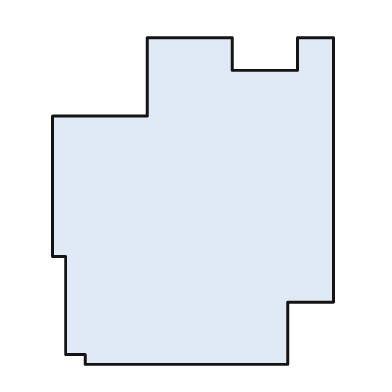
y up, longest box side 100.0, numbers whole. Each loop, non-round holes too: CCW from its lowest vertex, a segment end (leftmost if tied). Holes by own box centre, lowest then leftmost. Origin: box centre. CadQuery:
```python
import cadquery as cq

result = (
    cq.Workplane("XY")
    .moveTo(-33.0, -50.0)
    .lineTo(29.0, -50.0)
    .lineTo(29.0, -31.0)
    .lineTo(43.0, -31.0)
    .lineTo(43.0, 50.0)
    .lineTo(32.0, 50.0)
    .lineTo(32.0, 40.0)
    .lineTo(12.0, 40.0)
    .lineTo(12.0, 50.0)
    .lineTo(-14.0, 50.0)
    .lineTo(-14.0, 26.0)
    .lineTo(-43.0, 26.0)
    .lineTo(-43.0, -17.0)
    .lineTo(-39.0, -17.0)
    .lineTo(-39.0, -47.0)
    .lineTo(-33.0, -47.0)
    .close()
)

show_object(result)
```